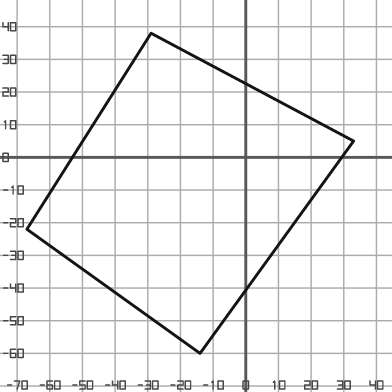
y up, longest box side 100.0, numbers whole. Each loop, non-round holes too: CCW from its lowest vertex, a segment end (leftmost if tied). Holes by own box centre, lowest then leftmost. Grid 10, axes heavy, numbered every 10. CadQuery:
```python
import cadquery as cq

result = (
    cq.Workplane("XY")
    .moveTo(-14.0, -60.0)
    .lineTo(33.0, 5.0)
    .lineTo(-29.0, 38.0)
    .lineTo(-67.0, -22.0)
    .close()
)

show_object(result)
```